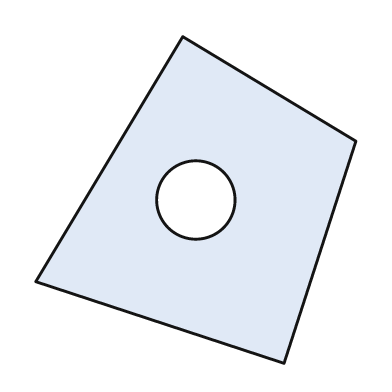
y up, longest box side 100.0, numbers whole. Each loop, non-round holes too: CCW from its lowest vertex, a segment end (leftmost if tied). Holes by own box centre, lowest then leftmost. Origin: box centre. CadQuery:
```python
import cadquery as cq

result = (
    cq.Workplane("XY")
    .moveTo(27.0, -50.0)
    .lineTo(49.0, 18.0)
    .lineTo(-4.0, 50.0)
    .lineTo(-49.0, -25.0)
    .close()
    .moveTo(0.0, 0.0)
    .circle(12.0)
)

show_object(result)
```